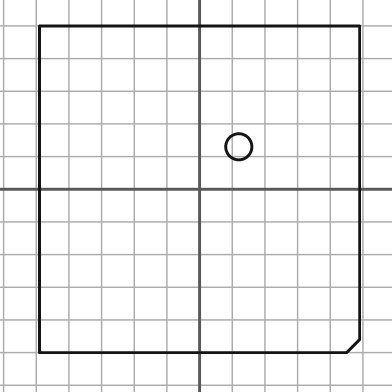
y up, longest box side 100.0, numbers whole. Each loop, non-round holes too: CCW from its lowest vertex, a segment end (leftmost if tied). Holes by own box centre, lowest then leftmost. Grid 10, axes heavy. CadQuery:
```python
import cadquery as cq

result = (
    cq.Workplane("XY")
    .moveTo(-49.0, -50.0)
    .lineTo(45.0, -50.0)
    .lineTo(49.0, -46.0)
    .lineTo(49.0, 50.0)
    .lineTo(-49.0, 50.0)
    .close()
    .moveTo(12.0, 13.0)
    .circle(4.0)
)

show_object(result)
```